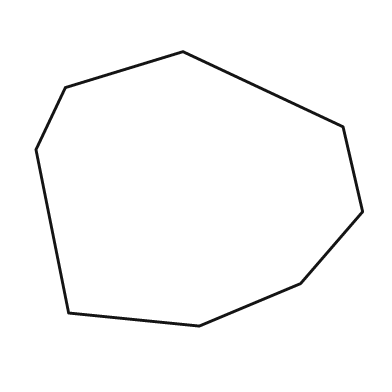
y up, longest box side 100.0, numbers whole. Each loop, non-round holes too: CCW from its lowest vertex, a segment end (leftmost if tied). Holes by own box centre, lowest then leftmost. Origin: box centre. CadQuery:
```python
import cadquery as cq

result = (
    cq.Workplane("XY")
    .moveTo(0.0, -42.0)
    .lineTo(31.0, -29.0)
    .lineTo(50.0, -7.0)
    .lineTo(44.0, 19.0)
    .lineTo(-5.0, 42.0)
    .lineTo(-41.0, 31.0)
    .lineTo(-50.0, 12.0)
    .lineTo(-40.0, -38.0)
    .close()
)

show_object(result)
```